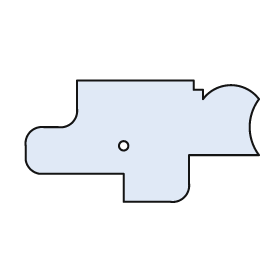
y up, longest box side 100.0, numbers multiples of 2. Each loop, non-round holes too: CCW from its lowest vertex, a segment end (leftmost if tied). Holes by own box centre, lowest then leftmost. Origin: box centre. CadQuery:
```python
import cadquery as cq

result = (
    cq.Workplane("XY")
    .moveTo(-8.0, -26.0)
    .lineTo(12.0, -26.0)
    .threePointArc((18.0, -24.0), (20.0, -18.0))
    .lineTo(20.0, -6.0)
    .lineTo(50.0, -6.0)
    .threePointArc((46.0, 6.0), (50.0, 18.0))
    .threePointArc((38.0, 24.0), (26.0, 18.0))
    .lineTo(26.0, 22.0)
    .lineTo(22.0, 22.0)
    .lineTo(22.0, 26.0)
    .lineTo(-28.0, 26.0)
    .lineTo(-28.0, 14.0)
    .threePointArc((-30.0, 8.0), (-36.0, 6.0))
    .lineTo(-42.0, 6.0)
    .threePointArc((-48.0, 4.0), (-50.0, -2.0))
    .lineTo(-50.0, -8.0)
    .threePointArc((-48.0, -12.0), (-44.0, -14.0))
    .lineTo(-8.0, -14.0)
    .close()
    .moveTo(-8.0, -2.0)
    .circle(2.0)
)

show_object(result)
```